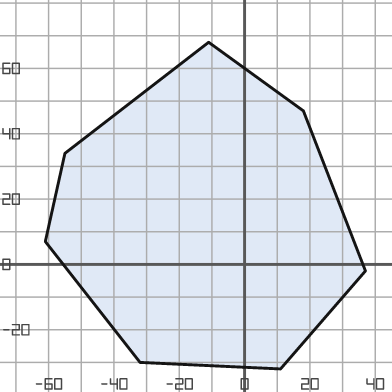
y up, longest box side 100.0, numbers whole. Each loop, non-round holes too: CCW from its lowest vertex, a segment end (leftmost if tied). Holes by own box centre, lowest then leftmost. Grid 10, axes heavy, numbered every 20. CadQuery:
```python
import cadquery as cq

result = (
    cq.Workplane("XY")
    .moveTo(11.0, -32.0)
    .lineTo(37.0, -2.0)
    .lineTo(18.0, 47.0)
    .lineTo(-11.0, 68.0)
    .lineTo(-55.0, 34.0)
    .lineTo(-61.0, 7.0)
    .lineTo(-32.0, -30.0)
    .close()
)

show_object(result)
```